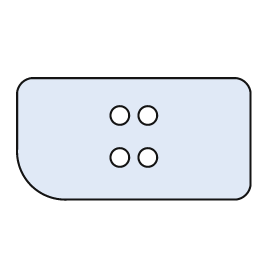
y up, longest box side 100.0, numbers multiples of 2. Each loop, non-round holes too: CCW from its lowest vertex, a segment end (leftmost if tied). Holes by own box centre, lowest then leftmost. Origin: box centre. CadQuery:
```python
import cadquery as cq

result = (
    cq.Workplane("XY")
    .moveTo(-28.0, -26.0)
    .lineTo(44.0, -26.0)
    .threePointArc((48.0, -24.0), (50.0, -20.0))
    .lineTo(50.0, 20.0)
    .threePointArc((48.0, 24.0), (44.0, 26.0))
    .lineTo(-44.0, 26.0)
    .threePointArc((-48.0, 24.0), (-50.0, 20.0))
    .lineTo(-50.0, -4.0)
    .threePointArc((-44.0, -20.0), (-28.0, -26.0))
    .close()
    .moveTo(-6.0, -8.0)
    .circle(4.0)
    .moveTo(6.0, -8.0)
    .circle(4.0)
    .moveTo(-6.0, 10.0)
    .circle(4.0)
    .moveTo(6.0, 10.0)
    .circle(4.0)
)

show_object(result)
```